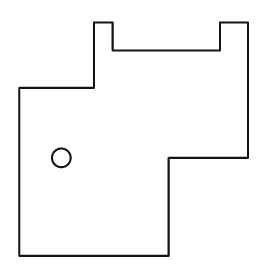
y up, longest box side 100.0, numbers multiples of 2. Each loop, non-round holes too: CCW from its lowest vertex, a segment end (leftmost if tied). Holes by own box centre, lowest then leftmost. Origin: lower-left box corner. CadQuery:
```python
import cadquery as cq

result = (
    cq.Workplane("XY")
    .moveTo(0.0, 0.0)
    .lineTo(64.0, 0.0)
    .lineTo(64.0, 42.0)
    .lineTo(98.0, 42.0)
    .lineTo(98.0, 100.0)
    .lineTo(86.0, 100.0)
    .lineTo(86.0, 88.0)
    .lineTo(40.0, 88.0)
    .lineTo(40.0, 100.0)
    .lineTo(32.0, 100.0)
    .lineTo(32.0, 72.0)
    .lineTo(0.0, 72.0)
    .close()
    .moveTo(18.0, 42.0)
    .circle(4.0)
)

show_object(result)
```